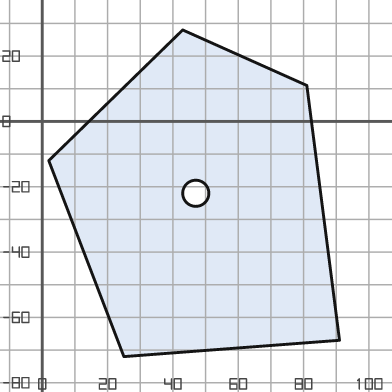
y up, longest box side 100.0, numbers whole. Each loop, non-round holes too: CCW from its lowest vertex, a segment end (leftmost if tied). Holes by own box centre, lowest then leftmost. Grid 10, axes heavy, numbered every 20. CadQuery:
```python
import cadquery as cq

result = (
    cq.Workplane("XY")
    .moveTo(25.0, -72.0)
    .lineTo(91.0, -67.0)
    .lineTo(81.0, 11.0)
    .lineTo(43.0, 28.0)
    .lineTo(2.0, -12.0)
    .close()
    .moveTo(47.0, -22.0)
    .circle(4.0)
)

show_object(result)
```